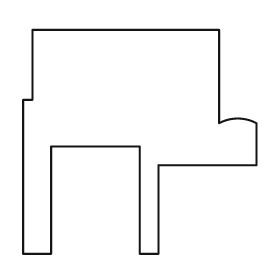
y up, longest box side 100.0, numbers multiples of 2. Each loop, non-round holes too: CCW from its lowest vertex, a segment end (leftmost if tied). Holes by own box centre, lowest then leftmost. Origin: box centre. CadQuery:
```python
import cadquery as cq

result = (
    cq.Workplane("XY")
    .moveTo(-50.0, -48.0)
    .lineTo(-38.0, -48.0)
    .lineTo(-38.0, -2.0)
    .lineTo(0.0, -2.0)
    .lineTo(0.0, -48.0)
    .lineTo(8.0, -48.0)
    .lineTo(8.0, -10.0)
    .lineTo(50.0, -10.0)
    .lineTo(50.0, 8.0)
    .threePointArc((42.0, 10.0), (34.0, 8.0))
    .lineTo(34.0, 48.0)
    .lineTo(-46.0, 48.0)
    .lineTo(-46.0, 18.0)
    .lineTo(-50.0, 18.0)
    .close()
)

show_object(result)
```